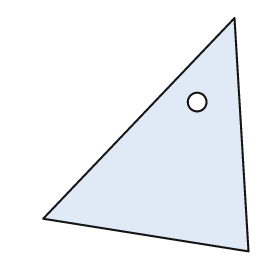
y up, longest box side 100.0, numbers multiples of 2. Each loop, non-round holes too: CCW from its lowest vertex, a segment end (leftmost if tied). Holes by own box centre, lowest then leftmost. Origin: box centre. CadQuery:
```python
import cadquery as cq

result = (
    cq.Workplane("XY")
    .moveTo(44.0, -50.0)
    .lineTo(38.0, 50.0)
    .lineTo(-44.0, -36.0)
    .close()
    .moveTo(22.0, 14.0)
    .circle(4.0)
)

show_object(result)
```